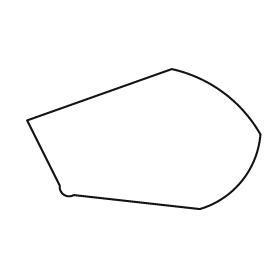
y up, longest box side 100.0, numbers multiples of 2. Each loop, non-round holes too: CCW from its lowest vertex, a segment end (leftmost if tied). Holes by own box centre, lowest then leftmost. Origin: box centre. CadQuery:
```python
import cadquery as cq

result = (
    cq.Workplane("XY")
    .moveTo(24.0, -30.0)
    .threePointArc((42.0, -18.0), (50.0, 2.0))
    .threePointArc((34.0, 20.0), (12.0, 30.0))
    .lineTo(-50.0, 8.0)
    .lineTo(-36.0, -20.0)
    .threePointArc((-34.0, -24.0), (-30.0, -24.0))
    .close()
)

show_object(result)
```